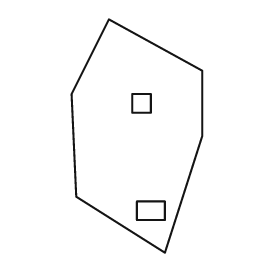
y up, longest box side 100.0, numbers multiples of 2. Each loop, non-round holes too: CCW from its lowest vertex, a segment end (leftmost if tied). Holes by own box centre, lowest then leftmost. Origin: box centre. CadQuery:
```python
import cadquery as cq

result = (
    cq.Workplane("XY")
    .moveTo(12.0, -50.0)
    .lineTo(28.0, 0.0)
    .lineTo(28.0, 28.0)
    .lineTo(-12.0, 50.0)
    .lineTo(-28.0, 18.0)
    .lineTo(-26.0, -26.0)
    .close()
    .moveTo(0.0, -36.0)
    .lineTo(12.0, -36.0)
    .lineTo(12.0, -28.0)
    .lineTo(0.0, -28.0)
    .close()
    .moveTo(-2.0, 10.0)
    .lineTo(6.0, 10.0)
    .lineTo(6.0, 18.0)
    .lineTo(-2.0, 18.0)
    .close()
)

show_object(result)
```